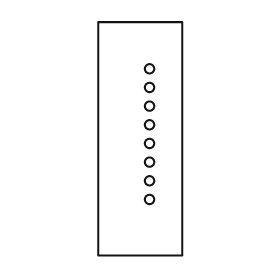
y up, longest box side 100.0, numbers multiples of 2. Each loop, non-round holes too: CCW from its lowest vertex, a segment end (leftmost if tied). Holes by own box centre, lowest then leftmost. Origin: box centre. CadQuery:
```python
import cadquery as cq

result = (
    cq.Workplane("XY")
    .moveTo(-18.0, -50.0)
    .lineTo(18.0, -50.0)
    .lineTo(18.0, 50.0)
    .lineTo(-18.0, 50.0)
    .close()
    .moveTo(4.0, -26.0)
    .circle(2.0)
    .moveTo(4.0, -18.0)
    .circle(2.0)
    .moveTo(4.0, -10.0)
    .circle(2.0)
    .moveTo(4.0, -2.0)
    .circle(2.0)
    .moveTo(4.0, 6.0)
    .circle(2.0)
    .moveTo(4.0, 14.0)
    .circle(2.0)
    .moveTo(4.0, 22.0)
    .circle(2.0)
    .moveTo(4.0, 30.0)
    .circle(2.0)
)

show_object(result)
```